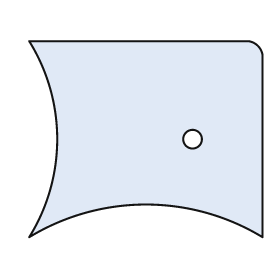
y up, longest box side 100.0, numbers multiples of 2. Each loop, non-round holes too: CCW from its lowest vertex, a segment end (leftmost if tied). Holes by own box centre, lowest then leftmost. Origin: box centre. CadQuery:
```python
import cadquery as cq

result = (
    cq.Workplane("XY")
    .moveTo(-50.0, -42.0)
    .threePointArc((0.0, -28.0), (50.0, -42.0))
    .lineTo(50.0, 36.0)
    .threePointArc((48.0, 40.0), (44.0, 42.0))
    .lineTo(-50.0, 42.0)
    .threePointArc((-38.0, 0.0), (-50.0, -42.0))
    .close()
    .moveTo(20.0, 0.0)
    .circle(4.0)
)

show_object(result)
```